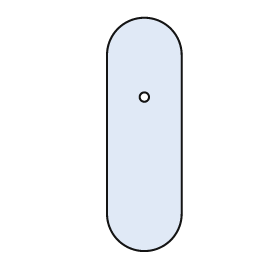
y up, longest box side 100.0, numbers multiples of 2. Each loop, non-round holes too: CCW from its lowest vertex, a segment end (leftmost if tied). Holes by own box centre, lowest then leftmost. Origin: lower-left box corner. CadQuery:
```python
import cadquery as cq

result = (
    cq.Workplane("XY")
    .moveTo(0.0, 16.0)
    .threePointArc((16.0, 0.0), (32.0, 16.0))
    .lineTo(32.0, 84.0)
    .threePointArc((16.0, 100.0), (0.0, 84.0))
    .close()
    .moveTo(16.0, 66.0)
    .circle(2.0)
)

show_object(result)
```